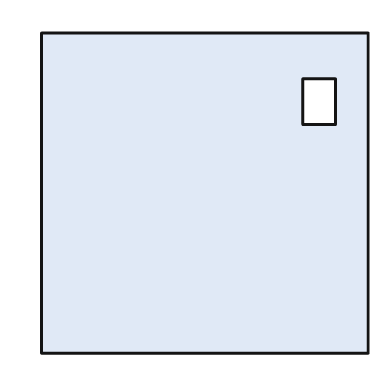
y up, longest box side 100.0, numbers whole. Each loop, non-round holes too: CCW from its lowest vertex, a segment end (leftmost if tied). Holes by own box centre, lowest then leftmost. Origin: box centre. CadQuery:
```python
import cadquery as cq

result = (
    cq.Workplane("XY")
    .moveTo(-50.0, -49.0)
    .lineTo(50.0, -49.0)
    .lineTo(50.0, 49.0)
    .lineTo(-50.0, 49.0)
    .close()
    .moveTo(30.0, 21.0)
    .lineTo(40.0, 21.0)
    .lineTo(40.0, 35.0)
    .lineTo(30.0, 35.0)
    .close()
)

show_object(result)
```